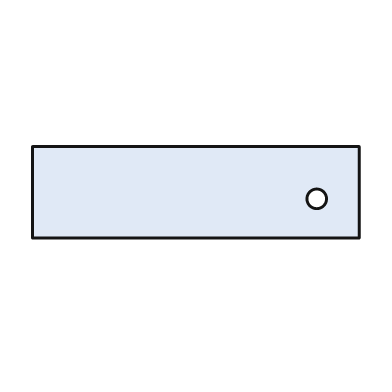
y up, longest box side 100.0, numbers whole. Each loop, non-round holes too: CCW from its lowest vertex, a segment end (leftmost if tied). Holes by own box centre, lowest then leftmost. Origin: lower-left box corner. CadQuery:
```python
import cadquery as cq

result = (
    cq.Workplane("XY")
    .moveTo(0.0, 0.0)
    .lineTo(100.0, 0.0)
    .lineTo(100.0, 28.0)
    .lineTo(0.0, 28.0)
    .close()
    .moveTo(87.0, 12.0)
    .circle(3.0)
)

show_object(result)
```